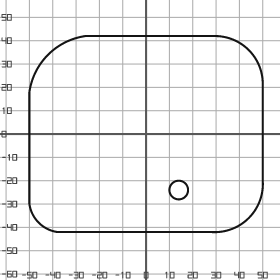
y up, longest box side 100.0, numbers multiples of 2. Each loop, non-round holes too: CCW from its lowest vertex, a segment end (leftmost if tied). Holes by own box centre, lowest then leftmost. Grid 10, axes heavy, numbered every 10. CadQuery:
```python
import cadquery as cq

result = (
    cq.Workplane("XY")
    .moveTo(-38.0, -42.0)
    .lineTo(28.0, -42.0)
    .threePointArc((44.0, -36.0), (50.0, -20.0))
    .lineTo(50.0, 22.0)
    .threePointArc((44.0, 36.0), (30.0, 42.0))
    .lineTo(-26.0, 42.0)
    .threePointArc((-42.0, 34.0), (-50.0, 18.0))
    .lineTo(-50.0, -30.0)
    .threePointArc((-46.0, -38.0), (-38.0, -42.0))
    .close()
    .moveTo(14.0, -24.0)
    .circle(4.0)
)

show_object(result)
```